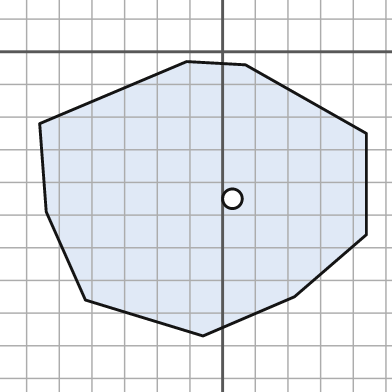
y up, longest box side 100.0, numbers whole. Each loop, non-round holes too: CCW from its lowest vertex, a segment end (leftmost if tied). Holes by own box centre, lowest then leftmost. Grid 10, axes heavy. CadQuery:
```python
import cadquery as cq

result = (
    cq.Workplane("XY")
    .moveTo(-6.0, -87.0)
    .lineTo(22.0, -75.0)
    .lineTo(44.0, -56.0)
    .lineTo(44.0, -25.0)
    .lineTo(7.0, -4.0)
    .lineTo(-11.0, -3.0)
    .lineTo(-56.0, -22.0)
    .lineTo(-54.0, -49.0)
    .lineTo(-42.0, -76.0)
    .close()
    .moveTo(3.0, -45.0)
    .circle(3.0)
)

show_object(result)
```